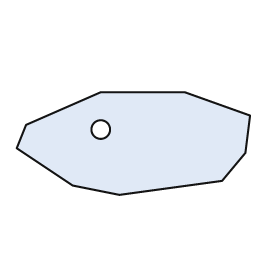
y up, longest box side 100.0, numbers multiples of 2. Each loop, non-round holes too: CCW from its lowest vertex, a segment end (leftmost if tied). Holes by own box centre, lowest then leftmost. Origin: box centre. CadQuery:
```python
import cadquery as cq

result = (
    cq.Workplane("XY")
    .moveTo(-6.0, -22.0)
    .lineTo(38.0, -16.0)
    .lineTo(48.0, -4.0)
    .lineTo(50.0, 12.0)
    .lineTo(22.0, 22.0)
    .lineTo(-14.0, 22.0)
    .lineTo(-46.0, 8.0)
    .lineTo(-50.0, -2.0)
    .lineTo(-26.0, -18.0)
    .close()
    .moveTo(-14.0, 6.0)
    .circle(4.0)
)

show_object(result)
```